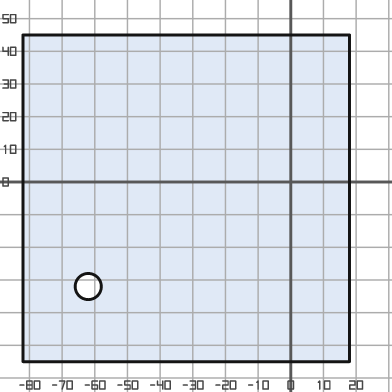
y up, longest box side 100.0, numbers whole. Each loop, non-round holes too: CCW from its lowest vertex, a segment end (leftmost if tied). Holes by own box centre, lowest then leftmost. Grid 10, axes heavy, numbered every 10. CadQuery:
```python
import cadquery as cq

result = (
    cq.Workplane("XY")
    .moveTo(-82.0, -55.0)
    .lineTo(18.0, -55.0)
    .lineTo(18.0, 45.0)
    .lineTo(-82.0, 45.0)
    .close()
    .moveTo(-62.0, -32.0)
    .circle(4.0)
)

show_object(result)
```